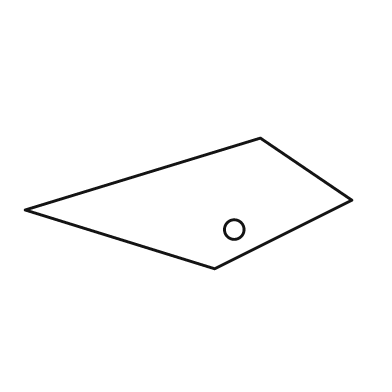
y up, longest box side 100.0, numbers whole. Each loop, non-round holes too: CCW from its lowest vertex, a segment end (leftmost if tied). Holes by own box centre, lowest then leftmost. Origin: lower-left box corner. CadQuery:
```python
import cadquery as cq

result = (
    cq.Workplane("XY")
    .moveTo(58.0, 0.0)
    .lineTo(100.0, 21.0)
    .lineTo(72.0, 40.0)
    .lineTo(0.0, 18.0)
    .close()
    .moveTo(64.0, 12.0)
    .circle(3.0)
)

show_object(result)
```